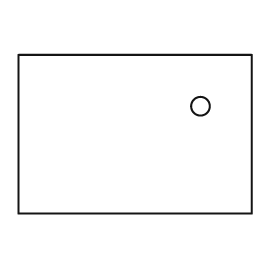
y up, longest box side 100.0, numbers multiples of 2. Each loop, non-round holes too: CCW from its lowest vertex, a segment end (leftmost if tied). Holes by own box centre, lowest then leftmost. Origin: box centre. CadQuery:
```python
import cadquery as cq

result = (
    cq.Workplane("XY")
    .moveTo(-50.0, -34.0)
    .lineTo(50.0, -34.0)
    .lineTo(50.0, 34.0)
    .lineTo(-50.0, 34.0)
    .close()
    .moveTo(28.0, 12.0)
    .circle(4.0)
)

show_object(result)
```